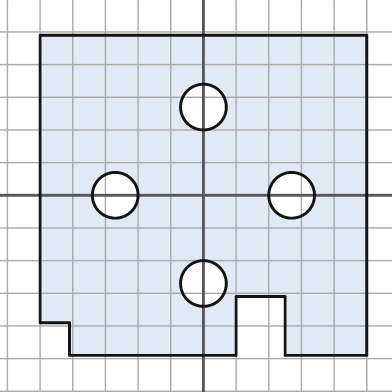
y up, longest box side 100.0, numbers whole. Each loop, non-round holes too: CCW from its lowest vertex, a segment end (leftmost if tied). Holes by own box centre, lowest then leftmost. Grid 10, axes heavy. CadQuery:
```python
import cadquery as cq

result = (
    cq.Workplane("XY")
    .moveTo(-41.0, -49.0)
    .lineTo(10.0, -49.0)
    .lineTo(10.0, -31.0)
    .lineTo(25.0, -31.0)
    .lineTo(25.0, -49.0)
    .lineTo(50.0, -49.0)
    .lineTo(50.0, 49.0)
    .lineTo(-50.0, 49.0)
    .lineTo(-50.0, -39.0)
    .lineTo(-41.0, -39.0)
    .close()
    .moveTo(0.0, -27.0)
    .circle(7.0)
    .moveTo(-27.0, 0.0)
    .circle(7.0)
    .moveTo(27.0, 0.0)
    .circle(7.0)
    .moveTo(0.0, 27.0)
    .circle(7.0)
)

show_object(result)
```